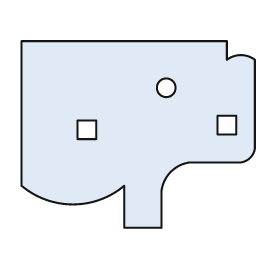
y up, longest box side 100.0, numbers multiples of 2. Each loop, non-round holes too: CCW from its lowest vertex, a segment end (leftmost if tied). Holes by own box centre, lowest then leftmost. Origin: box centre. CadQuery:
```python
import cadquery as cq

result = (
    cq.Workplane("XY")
    .moveTo(-6.0, -40.0)
    .lineTo(10.0, -40.0)
    .lineTo(10.0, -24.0)
    .threePointArc((14.0, -16.0), (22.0, -12.0))
    .lineTo(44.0, -12.0)
    .threePointArc((48.0, -10.0), (50.0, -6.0))
    .lineTo(50.0, 32.0)
    .threePointArc((44.0, 34.0), (38.0, 32.0))
    .lineTo(38.0, 40.0)
    .lineTo(-50.0, 40.0)
    .lineTo(-50.0, -22.0)
    .threePointArc((-28.0, -30.0), (-6.0, -22.0))
    .close()
    .moveTo(-26.0, -2.0)
    .lineTo(-18.0, -2.0)
    .lineTo(-18.0, 6.0)
    .lineTo(-26.0, 6.0)
    .close()
    .moveTo(34.0, 0.0)
    .lineTo(42.0, 0.0)
    .lineTo(42.0, 8.0)
    .lineTo(34.0, 8.0)
    .close()
    .moveTo(12.0, 20.0)
    .circle(4.0)
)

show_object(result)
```